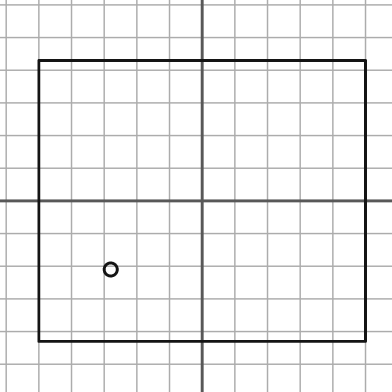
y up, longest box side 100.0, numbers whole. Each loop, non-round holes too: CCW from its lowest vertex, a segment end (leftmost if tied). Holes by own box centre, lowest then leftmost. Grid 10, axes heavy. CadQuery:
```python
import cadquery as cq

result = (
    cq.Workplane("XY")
    .moveTo(-50.0, -43.0)
    .lineTo(50.0, -43.0)
    .lineTo(50.0, 43.0)
    .lineTo(-50.0, 43.0)
    .close()
    .moveTo(-28.0, -21.0)
    .circle(2.0)
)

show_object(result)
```